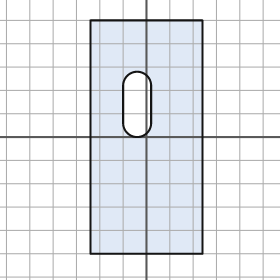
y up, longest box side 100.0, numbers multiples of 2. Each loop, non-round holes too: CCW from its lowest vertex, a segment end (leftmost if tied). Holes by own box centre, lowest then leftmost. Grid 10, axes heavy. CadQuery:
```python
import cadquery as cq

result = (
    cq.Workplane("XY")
    .moveTo(-24.0, -50.0)
    .lineTo(24.0, -50.0)
    .lineTo(24.0, 50.0)
    .lineTo(-24.0, 50.0)
    .close()
    .moveTo(-10.0, 6.0)
    .threePointArc((-4.0, 0.0), (2.0, 6.0))
    .lineTo(2.0, 22.0)
    .threePointArc((-4.0, 28.0), (-10.0, 22.0))
    .close()
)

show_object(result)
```